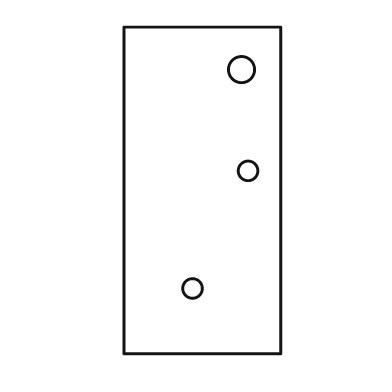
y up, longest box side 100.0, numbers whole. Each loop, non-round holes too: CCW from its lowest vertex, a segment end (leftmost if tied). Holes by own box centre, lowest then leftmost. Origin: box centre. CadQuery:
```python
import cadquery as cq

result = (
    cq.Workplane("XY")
    .moveTo(-24.0, -50.0)
    .lineTo(24.0, -50.0)
    .lineTo(24.0, 50.0)
    .lineTo(-24.0, 50.0)
    .close()
    .moveTo(-3.0, -30.0)
    .circle(3.0)
    .moveTo(14.0, 6.0)
    .circle(3.0)
    .moveTo(12.0, 37.0)
    .circle(4.0)
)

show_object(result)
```